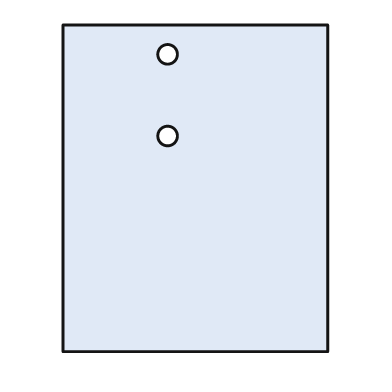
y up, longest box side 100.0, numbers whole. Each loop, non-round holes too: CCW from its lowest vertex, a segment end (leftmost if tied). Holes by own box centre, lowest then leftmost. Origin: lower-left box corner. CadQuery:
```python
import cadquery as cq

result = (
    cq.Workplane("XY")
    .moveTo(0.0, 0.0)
    .lineTo(81.0, 0.0)
    .lineTo(81.0, 100.0)
    .lineTo(0.0, 100.0)
    .close()
    .moveTo(32.0, 66.0)
    .circle(3.0)
    .moveTo(32.0, 91.0)
    .circle(3.0)
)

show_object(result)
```